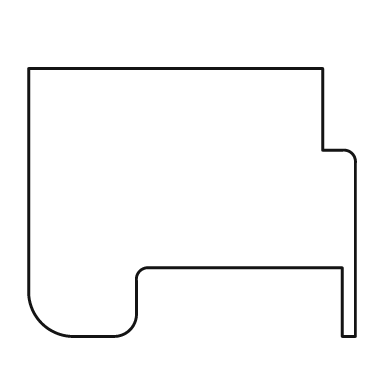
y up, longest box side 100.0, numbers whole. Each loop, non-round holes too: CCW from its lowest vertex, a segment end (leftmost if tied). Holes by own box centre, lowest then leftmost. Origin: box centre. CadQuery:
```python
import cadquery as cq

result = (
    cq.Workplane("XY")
    .moveTo(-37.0, -41.0)
    .lineTo(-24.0, -41.0)
    .threePointArc((-19.0, -39.0), (-17.0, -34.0))
    .lineTo(-17.0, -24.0)
    .threePointArc((-16.0, -21.0), (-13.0, -20.0))
    .lineTo(46.0, -20.0)
    .lineTo(46.0, -41.0)
    .lineTo(50.0, -41.0)
    .lineTo(50.0, 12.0)
    .threePointArc((49.0, 15.0), (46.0, 16.0))
    .lineTo(40.0, 16.0)
    .lineTo(40.0, 41.0)
    .lineTo(-50.0, 41.0)
    .lineTo(-50.0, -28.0)
    .threePointArc((-46.0, -37.0), (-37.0, -41.0))
    .close()
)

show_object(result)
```